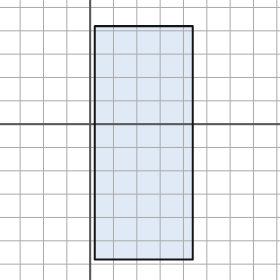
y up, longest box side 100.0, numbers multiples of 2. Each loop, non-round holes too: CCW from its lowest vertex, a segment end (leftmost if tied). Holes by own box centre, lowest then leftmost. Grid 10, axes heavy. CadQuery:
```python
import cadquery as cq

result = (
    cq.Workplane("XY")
    .moveTo(2.0, -58.0)
    .lineTo(44.0, -58.0)
    .lineTo(44.0, 42.0)
    .lineTo(2.0, 42.0)
    .close()
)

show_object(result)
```